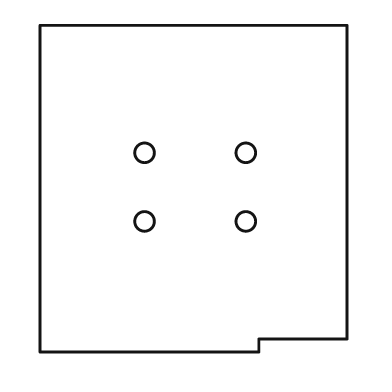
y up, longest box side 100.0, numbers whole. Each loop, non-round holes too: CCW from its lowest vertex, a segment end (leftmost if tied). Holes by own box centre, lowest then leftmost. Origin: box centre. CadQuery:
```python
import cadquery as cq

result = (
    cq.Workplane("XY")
    .moveTo(-47.0, -50.0)
    .lineTo(20.0, -50.0)
    .lineTo(20.0, -46.0)
    .lineTo(47.0, -46.0)
    .lineTo(47.0, 50.0)
    .lineTo(-47.0, 50.0)
    .close()
    .moveTo(-15.0, -10.0)
    .circle(3.0)
    .moveTo(16.0, -10.0)
    .circle(3.0)
    .moveTo(-15.0, 11.0)
    .circle(3.0)
    .moveTo(16.0, 11.0)
    .circle(3.0)
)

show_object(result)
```